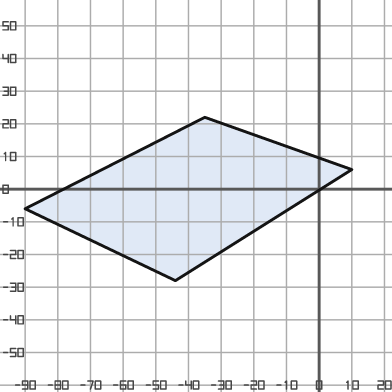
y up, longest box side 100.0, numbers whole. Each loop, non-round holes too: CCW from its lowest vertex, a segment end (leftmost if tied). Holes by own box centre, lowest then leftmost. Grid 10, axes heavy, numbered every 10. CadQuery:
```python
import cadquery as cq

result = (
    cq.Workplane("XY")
    .moveTo(-44.0, -28.0)
    .lineTo(10.0, 6.0)
    .lineTo(-35.0, 22.0)
    .lineTo(-90.0, -6.0)
    .close()
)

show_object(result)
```